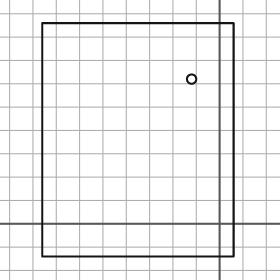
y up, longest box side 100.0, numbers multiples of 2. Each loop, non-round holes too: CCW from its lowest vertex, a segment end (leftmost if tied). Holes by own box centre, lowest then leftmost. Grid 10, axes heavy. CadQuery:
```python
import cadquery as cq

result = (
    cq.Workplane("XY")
    .moveTo(-76.0, -14.0)
    .lineTo(6.0, -14.0)
    .lineTo(6.0, 86.0)
    .lineTo(-76.0, 86.0)
    .close()
    .moveTo(-12.0, 62.0)
    .circle(2.0)
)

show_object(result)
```